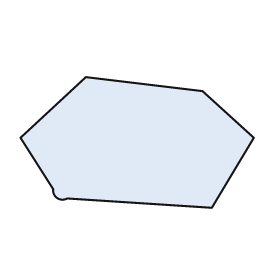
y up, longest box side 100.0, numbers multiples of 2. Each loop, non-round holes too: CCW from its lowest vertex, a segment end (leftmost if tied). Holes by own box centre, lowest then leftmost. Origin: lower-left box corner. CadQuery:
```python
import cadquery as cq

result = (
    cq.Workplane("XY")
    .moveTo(82.0, 0.0)
    .lineTo(100.0, 30.0)
    .lineTo(78.0, 50.0)
    .lineTo(28.0, 56.0)
    .lineTo(0.0, 30.0)
    .lineTo(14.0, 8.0)
    .threePointArc((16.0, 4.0), (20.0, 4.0))
    .close()
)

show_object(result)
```